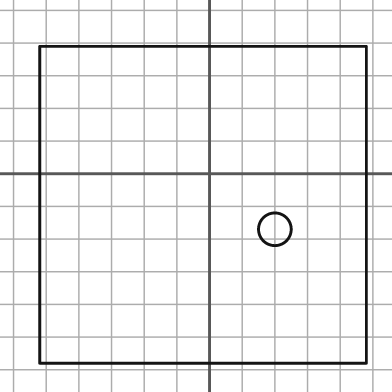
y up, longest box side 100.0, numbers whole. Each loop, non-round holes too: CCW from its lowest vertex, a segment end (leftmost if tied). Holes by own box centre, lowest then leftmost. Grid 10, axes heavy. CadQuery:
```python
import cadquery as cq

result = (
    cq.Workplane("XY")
    .moveTo(-52.0, -58.0)
    .lineTo(48.0, -58.0)
    .lineTo(48.0, 39.0)
    .lineTo(-52.0, 39.0)
    .close()
    .moveTo(20.0, -17.0)
    .circle(5.0)
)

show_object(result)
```